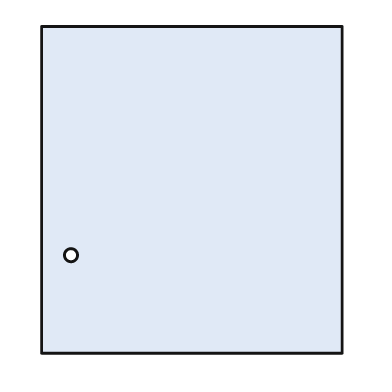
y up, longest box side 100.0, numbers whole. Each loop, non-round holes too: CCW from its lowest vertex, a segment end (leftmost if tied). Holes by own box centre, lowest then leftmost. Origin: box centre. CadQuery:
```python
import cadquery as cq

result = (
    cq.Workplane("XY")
    .moveTo(-46.0, -50.0)
    .lineTo(46.0, -50.0)
    .lineTo(46.0, 50.0)
    .lineTo(-46.0, 50.0)
    .close()
    .moveTo(-37.0, -20.0)
    .circle(2.0)
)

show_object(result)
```